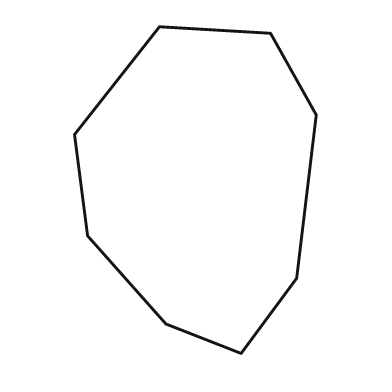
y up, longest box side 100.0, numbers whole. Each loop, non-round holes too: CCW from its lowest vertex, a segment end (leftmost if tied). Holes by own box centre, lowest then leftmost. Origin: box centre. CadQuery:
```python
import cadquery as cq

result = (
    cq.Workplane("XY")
    .moveTo(14.0, -50.0)
    .lineTo(31.0, -27.0)
    .lineTo(37.0, 23.0)
    .lineTo(23.0, 48.0)
    .lineTo(-11.0, 50.0)
    .lineTo(-37.0, 17.0)
    .lineTo(-33.0, -14.0)
    .lineTo(-9.0, -41.0)
    .close()
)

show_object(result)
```